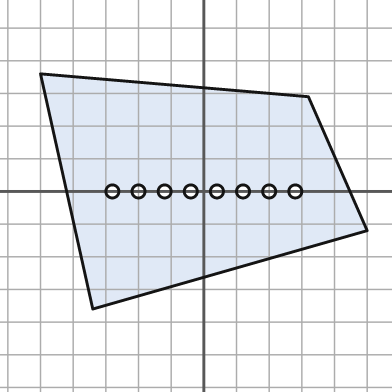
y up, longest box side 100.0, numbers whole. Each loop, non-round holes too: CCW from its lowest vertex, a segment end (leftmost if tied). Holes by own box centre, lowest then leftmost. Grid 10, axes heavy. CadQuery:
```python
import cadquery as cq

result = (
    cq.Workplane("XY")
    .moveTo(-34.0, -36.0)
    .lineTo(50.0, -12.0)
    .lineTo(32.0, 29.0)
    .lineTo(-50.0, 36.0)
    .close()
    .moveTo(-28.0, 0.0)
    .circle(2.0)
    .moveTo(-20.0, 0.0)
    .circle(2.0)
    .moveTo(-12.0, 0.0)
    .circle(2.0)
    .moveTo(-4.0, 0.0)
    .circle(2.0)
    .moveTo(4.0, 0.0)
    .circle(2.0)
    .moveTo(12.0, 0.0)
    .circle(2.0)
    .moveTo(20.0, 0.0)
    .circle(2.0)
    .moveTo(28.0, 0.0)
    .circle(2.0)
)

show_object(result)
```